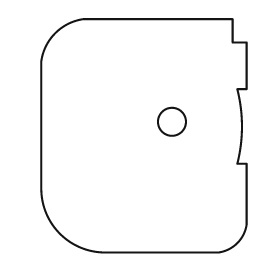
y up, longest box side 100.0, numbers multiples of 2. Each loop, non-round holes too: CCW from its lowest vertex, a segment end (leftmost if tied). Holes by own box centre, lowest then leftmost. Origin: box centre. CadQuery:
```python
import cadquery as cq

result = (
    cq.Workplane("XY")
    .moveTo(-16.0, -50.0)
    .lineTo(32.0, -50.0)
    .threePointArc((40.0, -46.0), (44.0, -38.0))
    .lineTo(44.0, -12.0)
    .lineTo(40.0, -12.0)
    .threePointArc((42.0, 4.0), (40.0, 20.0))
    .lineTo(44.0, 20.0)
    .lineTo(44.0, 40.0)
    .lineTo(38.0, 40.0)
    .lineTo(38.0, 50.0)
    .lineTo(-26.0, 50.0)
    .threePointArc((-38.0, 44.0), (-44.0, 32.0))
    .lineTo(-44.0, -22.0)
    .threePointArc((-36.0, -42.0), (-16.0, -50.0))
    .close()
    .moveTo(12.0, 6.0)
    .circle(6.0)
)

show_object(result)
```